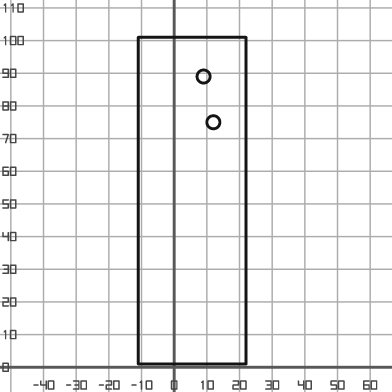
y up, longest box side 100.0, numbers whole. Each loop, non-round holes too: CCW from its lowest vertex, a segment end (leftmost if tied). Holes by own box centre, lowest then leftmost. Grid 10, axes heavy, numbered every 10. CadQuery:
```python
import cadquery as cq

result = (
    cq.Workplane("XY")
    .moveTo(-11.0, 1.0)
    .lineTo(22.0, 1.0)
    .lineTo(22.0, 101.0)
    .lineTo(-11.0, 101.0)
    .close()
    .moveTo(12.0, 75.0)
    .circle(2.0)
    .moveTo(9.0, 89.0)
    .circle(2.0)
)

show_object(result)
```